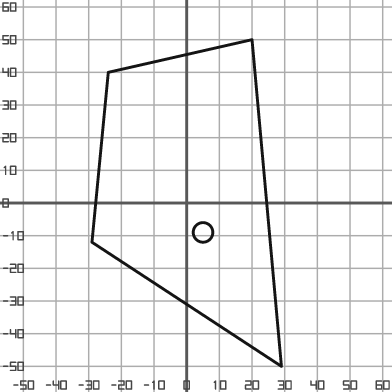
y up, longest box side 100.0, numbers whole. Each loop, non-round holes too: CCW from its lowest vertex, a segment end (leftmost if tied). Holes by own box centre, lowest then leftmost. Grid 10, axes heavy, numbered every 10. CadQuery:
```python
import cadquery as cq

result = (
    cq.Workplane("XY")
    .moveTo(29.0, -50.0)
    .lineTo(20.0, 50.0)
    .lineTo(-24.0, 40.0)
    .lineTo(-29.0, -12.0)
    .close()
    .moveTo(5.0, -9.0)
    .circle(3.0)
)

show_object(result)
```